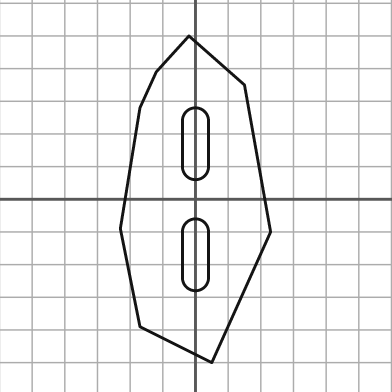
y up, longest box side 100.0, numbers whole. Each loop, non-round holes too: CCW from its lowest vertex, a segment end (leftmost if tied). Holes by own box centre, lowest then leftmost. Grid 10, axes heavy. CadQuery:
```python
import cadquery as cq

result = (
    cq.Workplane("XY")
    .moveTo(5.0, -50.0)
    .lineTo(23.0, -10.0)
    .lineTo(15.0, 35.0)
    .lineTo(-2.0, 50.0)
    .lineTo(-12.0, 39.0)
    .lineTo(-17.0, 28.0)
    .lineTo(-23.0, -9.0)
    .lineTo(-17.0, -39.0)
    .close()
    .moveTo(-4.0, -24.0)
    .threePointArc((0.0, -28.0), (4.0, -24.0))
    .lineTo(4.0, -10.0)
    .threePointArc((0.0, -6.0), (-4.0, -10.0))
    .close()
    .moveTo(-4.0, 10.0)
    .threePointArc((0.0, 6.0), (4.0, 10.0))
    .lineTo(4.0, 24.0)
    .threePointArc((0.0, 28.0), (-4.0, 24.0))
    .close()
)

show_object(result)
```